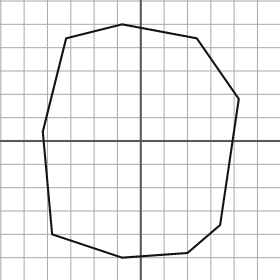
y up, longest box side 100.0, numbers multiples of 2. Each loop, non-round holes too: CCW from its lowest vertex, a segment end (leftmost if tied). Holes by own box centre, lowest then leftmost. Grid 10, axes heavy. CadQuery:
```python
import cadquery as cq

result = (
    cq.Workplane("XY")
    .moveTo(-8.0, -50.0)
    .lineTo(20.0, -48.0)
    .lineTo(34.0, -36.0)
    .lineTo(42.0, 18.0)
    .lineTo(24.0, 44.0)
    .lineTo(-8.0, 50.0)
    .lineTo(-32.0, 44.0)
    .lineTo(-42.0, 4.0)
    .lineTo(-38.0, -40.0)
    .close()
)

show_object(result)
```